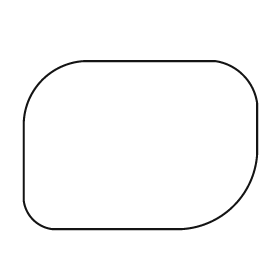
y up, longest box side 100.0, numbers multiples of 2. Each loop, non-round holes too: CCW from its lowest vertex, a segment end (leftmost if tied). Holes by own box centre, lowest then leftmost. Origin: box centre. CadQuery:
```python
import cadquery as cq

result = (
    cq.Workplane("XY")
    .moveTo(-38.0, -36.0)
    .lineTo(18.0, -36.0)
    .threePointArc((40.0, -26.0), (50.0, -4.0))
    .lineTo(50.0, 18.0)
    .threePointArc((44.0, 30.0), (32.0, 36.0))
    .lineTo(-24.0, 36.0)
    .threePointArc((-42.0, 28.0), (-50.0, 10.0))
    .lineTo(-50.0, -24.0)
    .threePointArc((-46.0, -32.0), (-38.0, -36.0))
    .close()
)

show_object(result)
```